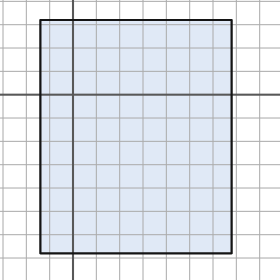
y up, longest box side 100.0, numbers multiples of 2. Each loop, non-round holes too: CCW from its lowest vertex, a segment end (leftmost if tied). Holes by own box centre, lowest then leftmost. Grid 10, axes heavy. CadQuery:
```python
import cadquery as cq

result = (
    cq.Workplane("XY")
    .moveTo(-14.0, -68.0)
    .lineTo(68.0, -68.0)
    .lineTo(68.0, 32.0)
    .lineTo(-14.0, 32.0)
    .close()
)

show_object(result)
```